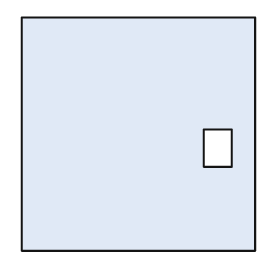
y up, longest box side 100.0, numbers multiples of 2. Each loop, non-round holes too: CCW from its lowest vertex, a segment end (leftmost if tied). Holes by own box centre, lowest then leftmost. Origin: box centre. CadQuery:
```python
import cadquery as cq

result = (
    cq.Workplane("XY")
    .moveTo(-50.0, -50.0)
    .lineTo(50.0, -50.0)
    .lineTo(50.0, 50.0)
    .lineTo(-50.0, 50.0)
    .close()
    .moveTo(28.0, -14.0)
    .lineTo(40.0, -14.0)
    .lineTo(40.0, 2.0)
    .lineTo(28.0, 2.0)
    .close()
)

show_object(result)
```